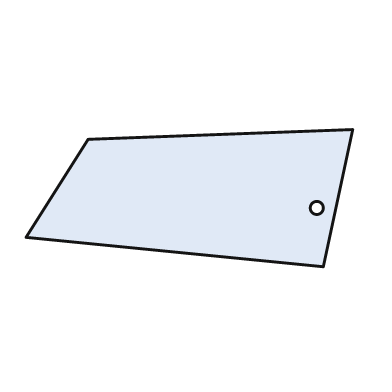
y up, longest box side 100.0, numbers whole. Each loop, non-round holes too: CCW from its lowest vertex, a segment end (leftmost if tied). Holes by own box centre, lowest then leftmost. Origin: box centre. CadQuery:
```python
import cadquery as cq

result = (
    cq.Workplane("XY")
    .moveTo(41.0, -21.0)
    .lineTo(50.0, 21.0)
    .lineTo(-31.0, 18.0)
    .lineTo(-50.0, -12.0)
    .close()
    .moveTo(39.0, -3.0)
    .circle(2.0)
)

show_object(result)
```